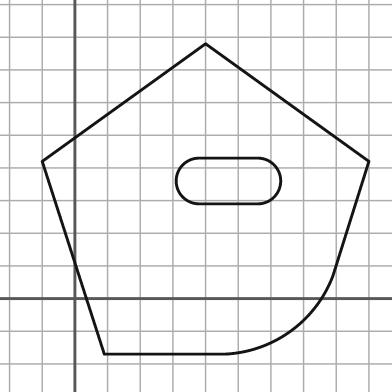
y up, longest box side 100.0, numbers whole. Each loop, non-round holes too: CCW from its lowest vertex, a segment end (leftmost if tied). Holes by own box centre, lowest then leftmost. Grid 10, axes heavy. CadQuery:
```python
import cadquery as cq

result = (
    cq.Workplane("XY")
    .moveTo(9.0, -17.0)
    .lineTo(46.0, -17.0)
    .threePointArc((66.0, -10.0), (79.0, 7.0))
    .lineTo(90.0, 42.0)
    .lineTo(40.0, 78.0)
    .lineTo(-10.0, 42.0)
    .close()
    .moveTo(38.0, 29.0)
    .lineTo(56.0, 29.0)
    .threePointArc((63.0, 36.0), (56.0, 43.0))
    .lineTo(38.0, 43.0)
    .threePointArc((31.0, 36.0), (38.0, 29.0))
    .close()
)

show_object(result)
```